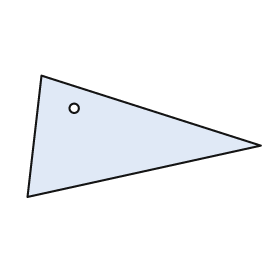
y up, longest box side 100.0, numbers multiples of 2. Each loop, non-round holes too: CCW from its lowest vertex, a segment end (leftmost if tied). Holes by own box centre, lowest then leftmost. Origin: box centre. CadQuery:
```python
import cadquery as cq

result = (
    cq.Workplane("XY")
    .moveTo(-50.0, -26.0)
    .lineTo(50.0, -4.0)
    .lineTo(-44.0, 26.0)
    .close()
    .moveTo(-30.0, 12.0)
    .circle(2.0)
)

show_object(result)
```